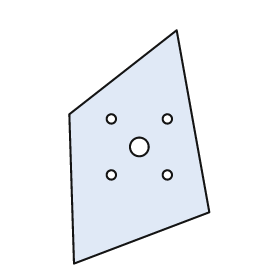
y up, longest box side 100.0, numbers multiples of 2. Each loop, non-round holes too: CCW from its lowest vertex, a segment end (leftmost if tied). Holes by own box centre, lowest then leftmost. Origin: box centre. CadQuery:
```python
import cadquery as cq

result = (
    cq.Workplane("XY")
    .moveTo(-28.0, -50.0)
    .lineTo(30.0, -28.0)
    .lineTo(16.0, 50.0)
    .lineTo(-30.0, 14.0)
    .close()
    .moveTo(-12.0, -12.0)
    .circle(2.0)
    .moveTo(12.0, -12.0)
    .circle(2.0)
    .moveTo(0.0, 0.0)
    .circle(4.0)
    .moveTo(-12.0, 12.0)
    .circle(2.0)
    .moveTo(12.0, 12.0)
    .circle(2.0)
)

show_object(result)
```